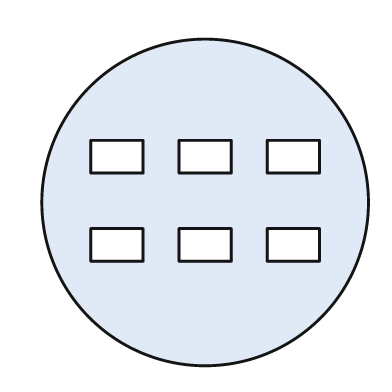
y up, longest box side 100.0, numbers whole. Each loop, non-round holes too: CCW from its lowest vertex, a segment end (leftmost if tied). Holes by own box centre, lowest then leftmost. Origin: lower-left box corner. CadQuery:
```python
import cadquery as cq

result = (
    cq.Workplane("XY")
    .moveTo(50.0, 50.0)
    .circle(50.0)
    .moveTo(15.0, 32.0)
    .lineTo(31.0, 32.0)
    .lineTo(31.0, 42.0)
    .lineTo(15.0, 42.0)
    .close()
    .moveTo(42.0, 32.0)
    .lineTo(58.0, 32.0)
    .lineTo(58.0, 42.0)
    .lineTo(42.0, 42.0)
    .close()
    .moveTo(69.0, 32.0)
    .lineTo(85.0, 32.0)
    .lineTo(85.0, 42.0)
    .lineTo(69.0, 42.0)
    .close()
    .moveTo(15.0, 59.0)
    .lineTo(31.0, 59.0)
    .lineTo(31.0, 69.0)
    .lineTo(15.0, 69.0)
    .close()
    .moveTo(42.0, 59.0)
    .lineTo(58.0, 59.0)
    .lineTo(58.0, 69.0)
    .lineTo(42.0, 69.0)
    .close()
    .moveTo(69.0, 59.0)
    .lineTo(85.0, 59.0)
    .lineTo(85.0, 69.0)
    .lineTo(69.0, 69.0)
    .close()
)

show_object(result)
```